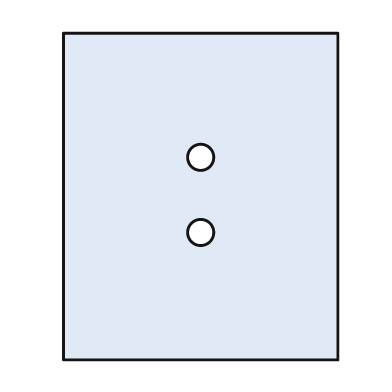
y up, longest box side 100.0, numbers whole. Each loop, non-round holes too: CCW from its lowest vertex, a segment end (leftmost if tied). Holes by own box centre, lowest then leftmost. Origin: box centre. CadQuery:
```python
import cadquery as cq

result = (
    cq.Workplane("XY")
    .moveTo(-42.0, -50.0)
    .lineTo(42.0, -50.0)
    .lineTo(42.0, 50.0)
    .lineTo(-42.0, 50.0)
    .close()
    .moveTo(0.0, -11.0)
    .circle(4.0)
    .moveTo(0.0, 12.0)
    .circle(4.0)
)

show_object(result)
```